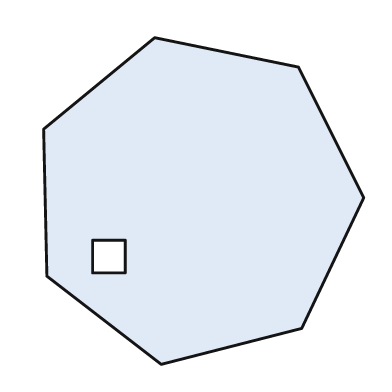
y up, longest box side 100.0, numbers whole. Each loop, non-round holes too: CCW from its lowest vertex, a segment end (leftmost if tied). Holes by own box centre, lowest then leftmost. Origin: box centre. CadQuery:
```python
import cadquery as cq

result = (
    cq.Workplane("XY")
    .moveTo(-13.0, -50.0)
    .lineTo(30.0, -39.0)
    .lineTo(49.0, 1.0)
    .lineTo(29.0, 41.0)
    .lineTo(-15.0, 50.0)
    .lineTo(-49.0, 22.0)
    .lineTo(-48.0, -23.0)
    .close()
    .moveTo(-34.0, -22.0)
    .lineTo(-24.0, -22.0)
    .lineTo(-24.0, -12.0)
    .lineTo(-34.0, -12.0)
    .close()
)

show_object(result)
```